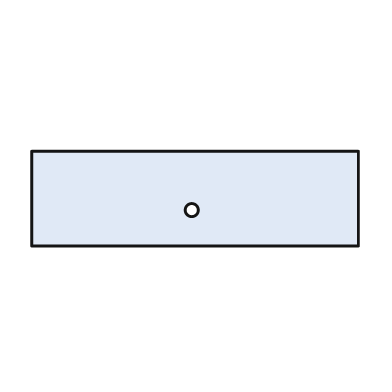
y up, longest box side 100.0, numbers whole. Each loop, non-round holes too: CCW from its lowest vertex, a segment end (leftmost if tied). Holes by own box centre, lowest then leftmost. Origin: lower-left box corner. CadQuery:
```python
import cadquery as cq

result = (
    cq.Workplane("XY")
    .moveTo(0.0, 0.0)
    .lineTo(100.0, 0.0)
    .lineTo(100.0, 29.0)
    .lineTo(0.0, 29.0)
    .close()
    .moveTo(49.0, 11.0)
    .circle(2.0)
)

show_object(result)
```